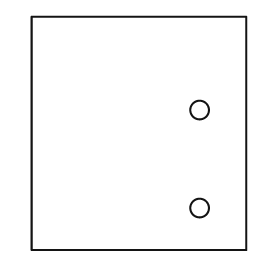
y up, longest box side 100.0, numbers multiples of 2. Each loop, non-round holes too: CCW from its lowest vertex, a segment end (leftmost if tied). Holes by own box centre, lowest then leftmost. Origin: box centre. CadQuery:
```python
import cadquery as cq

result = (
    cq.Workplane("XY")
    .moveTo(-46.0, -50.0)
    .lineTo(46.0, -50.0)
    .lineTo(46.0, 50.0)
    .lineTo(-46.0, 50.0)
    .close()
    .moveTo(26.0, -32.0)
    .circle(4.0)
    .moveTo(26.0, 10.0)
    .circle(4.0)
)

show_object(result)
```